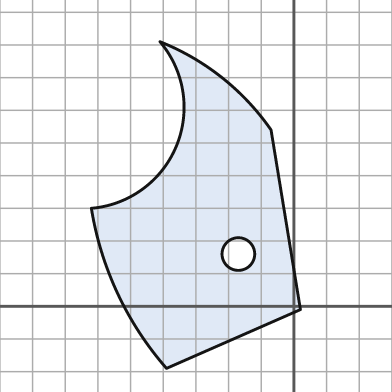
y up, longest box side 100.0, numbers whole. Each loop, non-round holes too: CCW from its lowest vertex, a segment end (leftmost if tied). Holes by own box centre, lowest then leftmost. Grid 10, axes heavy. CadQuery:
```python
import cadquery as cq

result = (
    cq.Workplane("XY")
    .moveTo(-39.0, -19.0)
    .lineTo(2.0, -1.0)
    .lineTo(-7.0, 54.0)
    .threePointArc((-22.0, 70.0), (-41.0, 81.0))
    .threePointArc((-36.0, 49.0), (-62.0, 30.0))
    .threePointArc((-54.0, 4.0), (-39.0, -19.0))
    .close()
    .moveTo(-17.0, 16.0)
    .circle(5.0)
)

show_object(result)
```